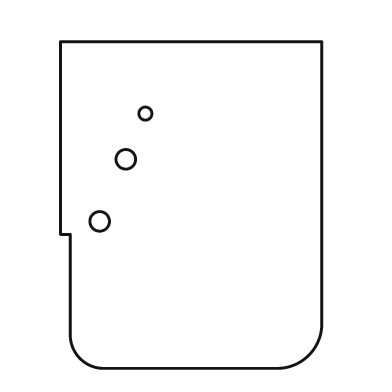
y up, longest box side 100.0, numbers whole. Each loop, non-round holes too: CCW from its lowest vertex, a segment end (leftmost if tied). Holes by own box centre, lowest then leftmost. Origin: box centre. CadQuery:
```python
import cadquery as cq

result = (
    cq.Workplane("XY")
    .moveTo(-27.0, -50.0)
    .lineTo(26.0, -50.0)
    .threePointArc((36.0, -46.0), (40.0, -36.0))
    .lineTo(40.0, 50.0)
    .lineTo(-40.0, 50.0)
    .lineTo(-40.0, -9.0)
    .lineTo(-37.0, -9.0)
    .lineTo(-37.0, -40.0)
    .threePointArc((-34.0, -47.0), (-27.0, -50.0))
    .close()
    .moveTo(-28.0, -5.0)
    .circle(3.0)
    .moveTo(-20.0, 14.0)
    .circle(3.0)
    .moveTo(-14.0, 28.0)
    .circle(2.0)
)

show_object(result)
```